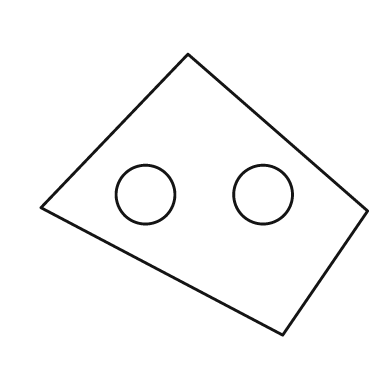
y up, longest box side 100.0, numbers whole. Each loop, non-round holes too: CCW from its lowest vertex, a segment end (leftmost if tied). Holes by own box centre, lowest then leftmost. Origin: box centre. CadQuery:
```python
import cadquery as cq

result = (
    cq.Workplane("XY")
    .moveTo(24.0, -43.0)
    .lineTo(50.0, -5.0)
    .lineTo(-5.0, 43.0)
    .lineTo(-50.0, -4.0)
    .close()
    .moveTo(-18.0, 0.0)
    .circle(9.0)
    .moveTo(18.0, 0.0)
    .circle(9.0)
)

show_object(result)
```